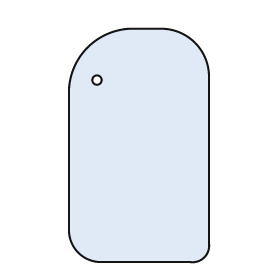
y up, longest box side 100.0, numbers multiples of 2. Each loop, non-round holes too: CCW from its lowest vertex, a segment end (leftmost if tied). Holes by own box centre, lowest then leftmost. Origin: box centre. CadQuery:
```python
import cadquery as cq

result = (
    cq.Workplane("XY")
    .moveTo(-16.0, -50.0)
    .lineTo(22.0, -50.0)
    .threePointArc((28.0, -48.0), (30.0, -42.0))
    .lineTo(30.0, 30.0)
    .threePointArc((24.0, 44.0), (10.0, 50.0))
    .lineTo(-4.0, 50.0)
    .threePointArc((-22.0, 42.0), (-30.0, 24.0))
    .lineTo(-30.0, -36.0)
    .threePointArc((-26.0, -46.0), (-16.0, -50.0))
    .close()
    .moveTo(-18.0, 28.0)
    .circle(2.0)
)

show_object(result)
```